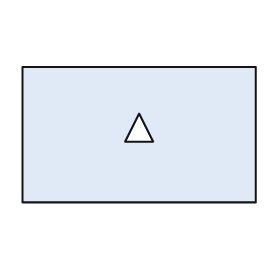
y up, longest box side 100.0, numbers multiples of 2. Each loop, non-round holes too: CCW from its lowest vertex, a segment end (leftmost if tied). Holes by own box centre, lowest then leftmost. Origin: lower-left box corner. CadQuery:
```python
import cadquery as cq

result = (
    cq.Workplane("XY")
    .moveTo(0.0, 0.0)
    .lineTo(100.0, 0.0)
    .lineTo(100.0, 58.0)
    .lineTo(0.0, 58.0)
    .close()
    .moveTo(44.0, 26.0)
    .lineTo(56.0, 26.0)
    .lineTo(50.0, 38.0)
    .close()
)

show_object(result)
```